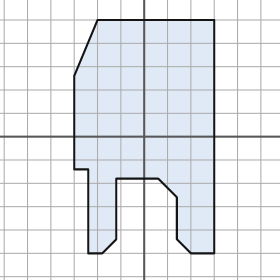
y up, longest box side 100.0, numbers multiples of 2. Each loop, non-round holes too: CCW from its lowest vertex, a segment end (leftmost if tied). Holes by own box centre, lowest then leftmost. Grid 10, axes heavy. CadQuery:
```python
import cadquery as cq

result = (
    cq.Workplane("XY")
    .moveTo(-24.0, -50.0)
    .lineTo(-18.0, -50.0)
    .lineTo(-12.0, -44.0)
    .lineTo(-12.0, -18.0)
    .lineTo(6.0, -18.0)
    .lineTo(14.0, -26.0)
    .lineTo(14.0, -44.0)
    .lineTo(20.0, -50.0)
    .lineTo(30.0, -50.0)
    .lineTo(30.0, 50.0)
    .lineTo(-20.0, 50.0)
    .lineTo(-30.0, 26.0)
    .lineTo(-30.0, -14.0)
    .lineTo(-24.0, -14.0)
    .close()
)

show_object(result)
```